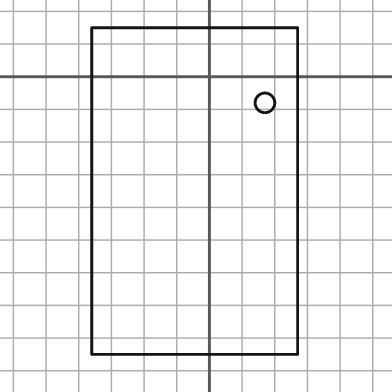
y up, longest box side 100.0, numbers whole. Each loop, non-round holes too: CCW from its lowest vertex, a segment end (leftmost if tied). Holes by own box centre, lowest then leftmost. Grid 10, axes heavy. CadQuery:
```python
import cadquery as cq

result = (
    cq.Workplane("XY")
    .moveTo(-36.0, -85.0)
    .lineTo(27.0, -85.0)
    .lineTo(27.0, 15.0)
    .lineTo(-36.0, 15.0)
    .close()
    .moveTo(17.0, -8.0)
    .circle(3.0)
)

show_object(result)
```